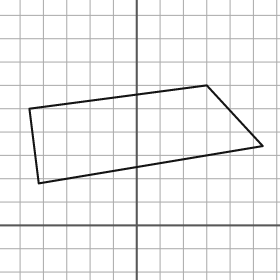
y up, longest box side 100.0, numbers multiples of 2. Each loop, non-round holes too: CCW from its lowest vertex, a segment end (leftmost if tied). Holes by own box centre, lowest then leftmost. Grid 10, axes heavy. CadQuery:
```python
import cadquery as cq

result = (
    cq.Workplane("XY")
    .moveTo(-42.0, 18.0)
    .lineTo(54.0, 34.0)
    .lineTo(30.0, 60.0)
    .lineTo(-46.0, 50.0)
    .close()
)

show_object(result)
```